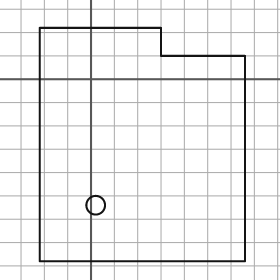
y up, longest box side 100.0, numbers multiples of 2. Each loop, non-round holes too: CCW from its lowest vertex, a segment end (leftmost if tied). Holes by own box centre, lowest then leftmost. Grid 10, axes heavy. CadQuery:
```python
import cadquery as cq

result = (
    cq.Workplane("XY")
    .moveTo(-22.0, -78.0)
    .lineTo(66.0, -78.0)
    .lineTo(66.0, 10.0)
    .lineTo(30.0, 10.0)
    .lineTo(30.0, 22.0)
    .lineTo(-22.0, 22.0)
    .close()
    .moveTo(2.0, -54.0)
    .circle(4.0)
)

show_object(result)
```